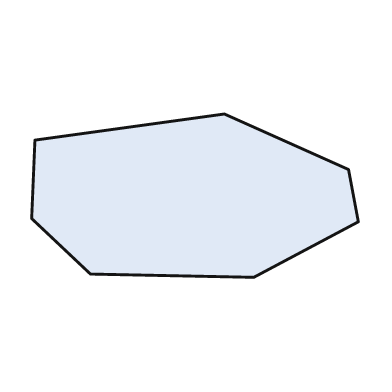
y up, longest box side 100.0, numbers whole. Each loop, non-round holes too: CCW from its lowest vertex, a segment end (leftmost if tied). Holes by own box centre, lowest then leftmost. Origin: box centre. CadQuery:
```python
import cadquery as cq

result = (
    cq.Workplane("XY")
    .moveTo(18.0, -25.0)
    .lineTo(50.0, -8.0)
    .lineTo(47.0, 8.0)
    .lineTo(9.0, 25.0)
    .lineTo(-49.0, 17.0)
    .lineTo(-50.0, -7.0)
    .lineTo(-32.0, -24.0)
    .close()
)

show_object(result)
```